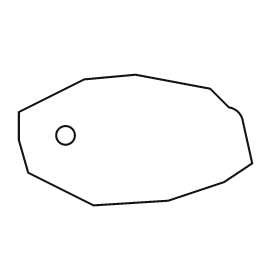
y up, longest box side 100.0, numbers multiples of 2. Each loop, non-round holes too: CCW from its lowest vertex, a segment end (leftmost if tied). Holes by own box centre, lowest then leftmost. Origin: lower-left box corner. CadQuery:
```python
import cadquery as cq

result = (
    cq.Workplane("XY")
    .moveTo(32.0, 0.0)
    .lineTo(64.0, 2.0)
    .lineTo(88.0, 10.0)
    .lineTo(100.0, 18.0)
    .lineTo(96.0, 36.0)
    .threePointArc((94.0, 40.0), (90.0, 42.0))
    .lineTo(82.0, 50.0)
    .lineTo(50.0, 56.0)
    .lineTo(28.0, 54.0)
    .lineTo(0.0, 40.0)
    .lineTo(0.0, 28.0)
    .lineTo(4.0, 14.0)
    .close()
    .moveTo(20.0, 30.0)
    .circle(4.0)
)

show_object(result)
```